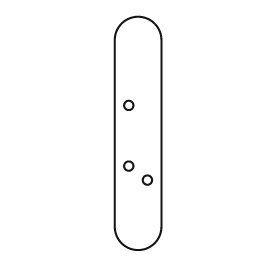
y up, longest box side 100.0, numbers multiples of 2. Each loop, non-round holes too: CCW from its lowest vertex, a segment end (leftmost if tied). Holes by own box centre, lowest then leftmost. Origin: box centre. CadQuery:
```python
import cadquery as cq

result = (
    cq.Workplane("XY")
    .moveTo(-10.0, -40.0)
    .threePointArc((0.0, -50.0), (10.0, -40.0))
    .lineTo(10.0, 40.0)
    .threePointArc((0.0, 50.0), (-10.0, 40.0))
    .close()
    .moveTo(4.0, -20.0)
    .circle(2.0)
    .moveTo(-4.0, -14.0)
    .circle(2.0)
    .moveTo(-4.0, 12.0)
    .circle(2.0)
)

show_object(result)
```